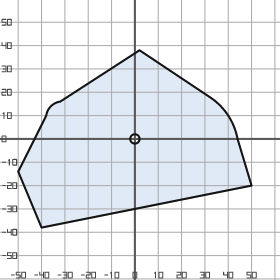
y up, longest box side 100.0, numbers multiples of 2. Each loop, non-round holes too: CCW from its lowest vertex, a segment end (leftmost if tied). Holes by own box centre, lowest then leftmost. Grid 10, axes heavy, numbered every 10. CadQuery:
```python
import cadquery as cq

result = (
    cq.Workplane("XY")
    .moveTo(-40.0, -38.0)
    .lineTo(50.0, -20.0)
    .lineTo(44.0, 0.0)
    .threePointArc((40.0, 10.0), (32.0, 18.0))
    .lineTo(2.0, 38.0)
    .lineTo(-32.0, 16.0)
    .threePointArc((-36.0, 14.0), (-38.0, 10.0))
    .lineTo(-50.0, -14.0)
    .close()
    .moveTo(0.0, 0.0)
    .circle(2.0)
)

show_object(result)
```